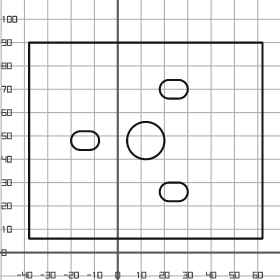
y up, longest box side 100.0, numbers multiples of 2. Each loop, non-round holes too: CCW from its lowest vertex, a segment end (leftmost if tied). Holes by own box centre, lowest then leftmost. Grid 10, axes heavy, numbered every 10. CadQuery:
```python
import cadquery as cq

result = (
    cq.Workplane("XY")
    .moveTo(-38.0, 6.0)
    .lineTo(62.0, 6.0)
    .lineTo(62.0, 90.0)
    .lineTo(-38.0, 90.0)
    .close()
    .moveTo(22.0, 22.0)
    .lineTo(26.0, 22.0)
    .threePointArc((30.0, 26.0), (26.0, 30.0))
    .lineTo(22.0, 30.0)
    .threePointArc((18.0, 26.0), (22.0, 22.0))
    .close()
    .moveTo(-16.0, 44.0)
    .lineTo(-12.0, 44.0)
    .threePointArc((-8.0, 48.0), (-12.0, 52.0))
    .lineTo(-16.0, 52.0)
    .threePointArc((-20.0, 48.0), (-16.0, 44.0))
    .close()
    .moveTo(12.0, 48.0)
    .circle(8.0)
    .moveTo(22.0, 66.0)
    .lineTo(26.0, 66.0)
    .threePointArc((30.0, 70.0), (26.0, 74.0))
    .lineTo(22.0, 74.0)
    .threePointArc((18.0, 70.0), (22.0, 66.0))
    .close()
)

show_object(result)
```